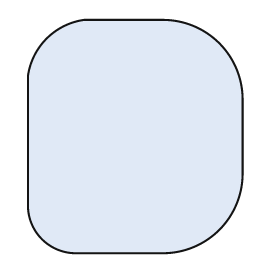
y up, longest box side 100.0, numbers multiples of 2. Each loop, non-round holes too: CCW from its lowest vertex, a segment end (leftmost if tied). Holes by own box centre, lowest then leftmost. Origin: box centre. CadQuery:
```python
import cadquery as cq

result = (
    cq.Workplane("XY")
    .moveTo(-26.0, -50.0)
    .lineTo(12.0, -50.0)
    .threePointArc((36.0, -40.0), (46.0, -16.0))
    .lineTo(46.0, 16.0)
    .threePointArc((36.0, 40.0), (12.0, 50.0))
    .lineTo(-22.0, 50.0)
    .threePointArc((-38.0, 42.0), (-46.0, 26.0))
    .lineTo(-46.0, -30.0)
    .threePointArc((-40.0, -44.0), (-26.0, -50.0))
    .close()
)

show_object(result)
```